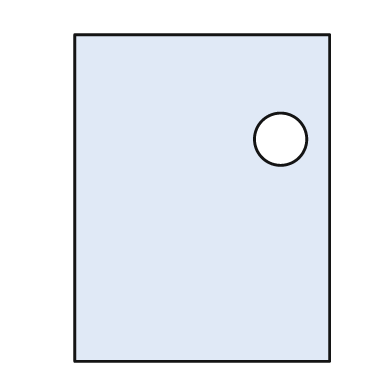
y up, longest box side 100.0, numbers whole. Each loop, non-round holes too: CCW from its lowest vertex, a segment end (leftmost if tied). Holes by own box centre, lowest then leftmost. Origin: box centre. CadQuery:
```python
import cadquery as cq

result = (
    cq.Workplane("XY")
    .moveTo(-39.0, -50.0)
    .lineTo(39.0, -50.0)
    .lineTo(39.0, 50.0)
    .lineTo(-39.0, 50.0)
    .close()
    .moveTo(24.0, 18.0)
    .circle(8.0)
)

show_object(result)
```